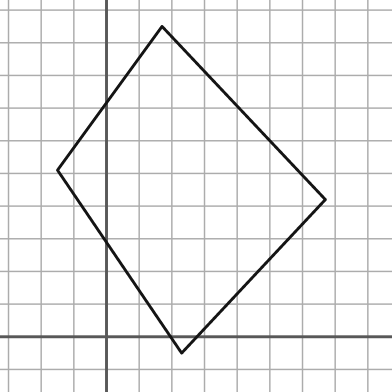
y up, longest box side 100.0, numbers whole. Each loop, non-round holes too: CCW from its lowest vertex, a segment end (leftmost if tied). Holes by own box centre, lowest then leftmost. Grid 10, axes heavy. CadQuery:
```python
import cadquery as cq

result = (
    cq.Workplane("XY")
    .moveTo(23.0, -5.0)
    .lineTo(67.0, 42.0)
    .lineTo(17.0, 95.0)
    .lineTo(-15.0, 51.0)
    .close()
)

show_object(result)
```